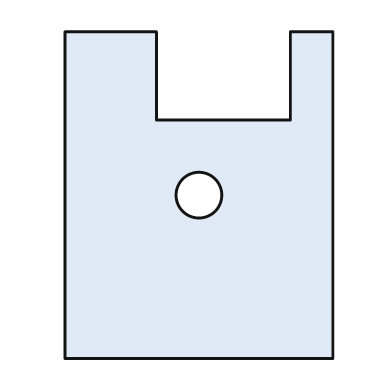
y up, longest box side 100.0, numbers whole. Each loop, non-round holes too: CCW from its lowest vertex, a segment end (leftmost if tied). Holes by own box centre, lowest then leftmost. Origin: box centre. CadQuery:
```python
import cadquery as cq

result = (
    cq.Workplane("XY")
    .moveTo(-41.0, -50.0)
    .lineTo(41.0, -50.0)
    .lineTo(41.0, 50.0)
    .lineTo(28.0, 50.0)
    .lineTo(28.0, 23.0)
    .lineTo(-13.0, 23.0)
    .lineTo(-13.0, 50.0)
    .lineTo(-41.0, 50.0)
    .close()
    .moveTo(0.0, 0.0)
    .circle(7.0)
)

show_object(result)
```